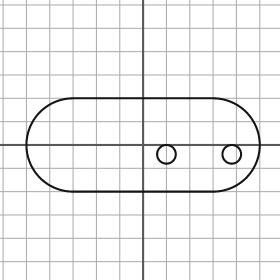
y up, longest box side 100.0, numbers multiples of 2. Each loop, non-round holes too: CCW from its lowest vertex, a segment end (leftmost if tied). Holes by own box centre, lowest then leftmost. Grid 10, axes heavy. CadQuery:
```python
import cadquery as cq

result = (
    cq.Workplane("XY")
    .moveTo(-30.0, -20.0)
    .lineTo(30.0, -20.0)
    .threePointArc((50.0, 0.0), (30.0, 20.0))
    .lineTo(-30.0, 20.0)
    .threePointArc((-50.0, 0.0), (-30.0, -20.0))
    .close()
    .moveTo(10.0, -4.0)
    .circle(4.0)
    .moveTo(38.0, -4.0)
    .circle(4.0)
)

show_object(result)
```